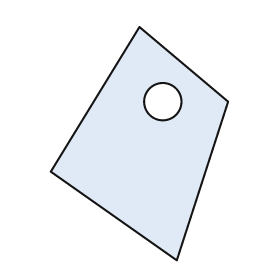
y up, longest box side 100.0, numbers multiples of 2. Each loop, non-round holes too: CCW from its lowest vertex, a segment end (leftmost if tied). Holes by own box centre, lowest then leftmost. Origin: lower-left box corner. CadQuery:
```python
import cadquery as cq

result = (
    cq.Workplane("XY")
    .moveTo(54.0, 0.0)
    .lineTo(76.0, 68.0)
    .lineTo(38.0, 100.0)
    .lineTo(0.0, 38.0)
    .close()
    .moveTo(48.0, 68.0)
    .circle(8.0)
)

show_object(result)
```